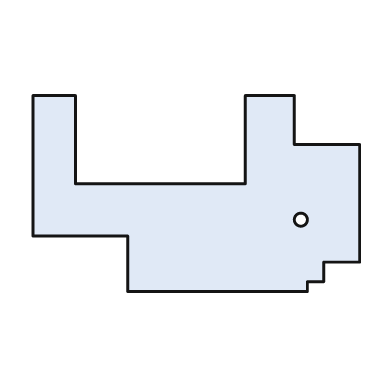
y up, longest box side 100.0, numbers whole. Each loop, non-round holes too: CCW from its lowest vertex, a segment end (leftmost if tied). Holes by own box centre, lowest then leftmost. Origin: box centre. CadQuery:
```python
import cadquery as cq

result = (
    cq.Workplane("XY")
    .moveTo(-21.0, -30.0)
    .lineTo(34.0, -30.0)
    .lineTo(34.0, -27.0)
    .lineTo(39.0, -27.0)
    .lineTo(39.0, -21.0)
    .lineTo(50.0, -21.0)
    .lineTo(50.0, 15.0)
    .lineTo(30.0, 15.0)
    .lineTo(30.0, 30.0)
    .lineTo(15.0, 30.0)
    .lineTo(15.0, 3.0)
    .lineTo(-37.0, 3.0)
    .lineTo(-37.0, 30.0)
    .lineTo(-50.0, 30.0)
    .lineTo(-50.0, -13.0)
    .lineTo(-21.0, -13.0)
    .close()
    .moveTo(32.0, -8.0)
    .circle(2.0)
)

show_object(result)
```